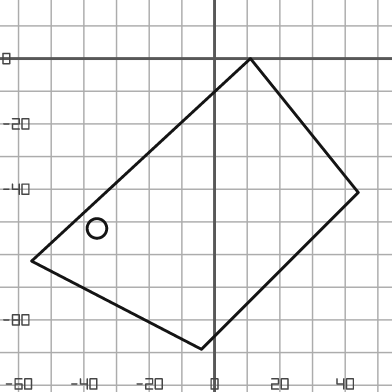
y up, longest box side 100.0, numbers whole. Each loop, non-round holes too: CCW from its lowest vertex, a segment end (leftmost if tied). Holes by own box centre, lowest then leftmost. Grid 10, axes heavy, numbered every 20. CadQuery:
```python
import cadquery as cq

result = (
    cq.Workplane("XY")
    .moveTo(-4.0, -89.0)
    .lineTo(44.0, -41.0)
    .lineTo(11.0, 0.0)
    .lineTo(-56.0, -62.0)
    .close()
    .moveTo(-36.0, -52.0)
    .circle(3.0)
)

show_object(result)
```